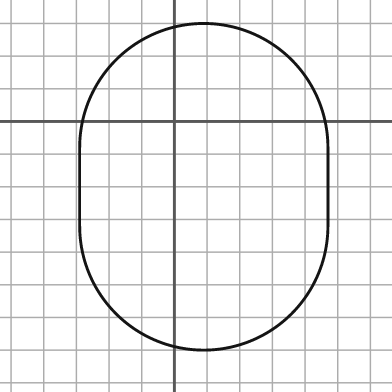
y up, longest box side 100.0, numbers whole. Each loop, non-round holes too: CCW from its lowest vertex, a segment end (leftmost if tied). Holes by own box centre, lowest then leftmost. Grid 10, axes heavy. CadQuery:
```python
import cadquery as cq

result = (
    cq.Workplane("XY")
    .moveTo(-29.0, -32.0)
    .threePointArc((9.0, -70.0), (47.0, -32.0))
    .lineTo(47.0, -8.0)
    .threePointArc((9.0, 30.0), (-29.0, -8.0))
    .close()
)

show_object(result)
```